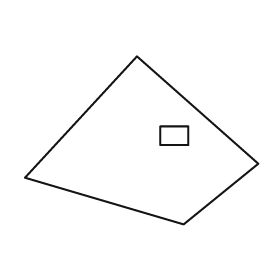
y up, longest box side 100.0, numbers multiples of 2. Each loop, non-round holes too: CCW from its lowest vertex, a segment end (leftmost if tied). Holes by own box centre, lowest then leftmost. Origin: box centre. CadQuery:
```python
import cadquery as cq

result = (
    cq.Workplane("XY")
    .moveTo(18.0, -36.0)
    .lineTo(50.0, -10.0)
    .lineTo(-2.0, 36.0)
    .lineTo(-50.0, -16.0)
    .close()
    .moveTo(8.0, -2.0)
    .lineTo(20.0, -2.0)
    .lineTo(20.0, 6.0)
    .lineTo(8.0, 6.0)
    .close()
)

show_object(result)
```